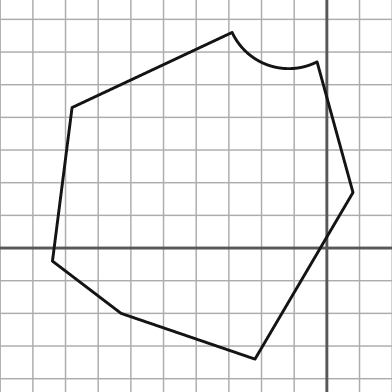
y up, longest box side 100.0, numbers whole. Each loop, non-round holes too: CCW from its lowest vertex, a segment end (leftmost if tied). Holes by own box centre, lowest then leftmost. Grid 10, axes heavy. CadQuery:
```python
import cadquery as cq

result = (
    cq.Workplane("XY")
    .moveTo(-22.0, -34.0)
    .lineTo(8.0, 17.0)
    .lineTo(-3.0, 57.0)
    .threePointArc((-18.0, 56.0), (-29.0, 66.0))
    .lineTo(-78.0, 43.0)
    .lineTo(-84.0, -4.0)
    .lineTo(-63.0, -20.0)
    .close()
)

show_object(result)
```